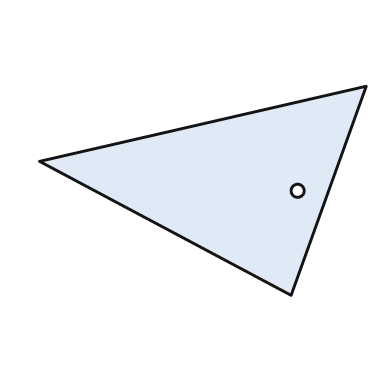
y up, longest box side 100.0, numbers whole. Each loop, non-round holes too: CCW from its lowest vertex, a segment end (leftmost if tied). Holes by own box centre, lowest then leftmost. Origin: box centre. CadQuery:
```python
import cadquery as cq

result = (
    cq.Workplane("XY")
    .moveTo(27.0, -32.0)
    .lineTo(50.0, 32.0)
    .lineTo(-50.0, 9.0)
    .close()
    .moveTo(29.0, 0.0)
    .circle(2.0)
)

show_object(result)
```